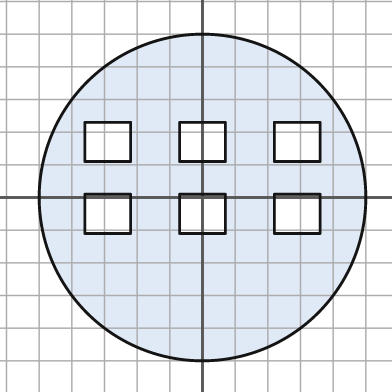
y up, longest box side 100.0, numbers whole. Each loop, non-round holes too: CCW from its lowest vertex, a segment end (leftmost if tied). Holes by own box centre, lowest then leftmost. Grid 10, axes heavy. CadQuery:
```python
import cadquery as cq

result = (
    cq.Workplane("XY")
    .moveTo(0.0, 0.0)
    .circle(50.0)
    .moveTo(-36.0, -11.0)
    .lineTo(-22.0, -11.0)
    .lineTo(-22.0, 1.0)
    .lineTo(-36.0, 1.0)
    .close()
    .moveTo(-7.0, -11.0)
    .lineTo(7.0, -11.0)
    .lineTo(7.0, 1.0)
    .lineTo(-7.0, 1.0)
    .close()
    .moveTo(22.0, -11.0)
    .lineTo(36.0, -11.0)
    .lineTo(36.0, 1.0)
    .lineTo(22.0, 1.0)
    .close()
    .moveTo(-36.0, 11.0)
    .lineTo(-22.0, 11.0)
    .lineTo(-22.0, 23.0)
    .lineTo(-36.0, 23.0)
    .close()
    .moveTo(-7.0, 11.0)
    .lineTo(7.0, 11.0)
    .lineTo(7.0, 23.0)
    .lineTo(-7.0, 23.0)
    .close()
    .moveTo(22.0, 11.0)
    .lineTo(36.0, 11.0)
    .lineTo(36.0, 23.0)
    .lineTo(22.0, 23.0)
    .close()
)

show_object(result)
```